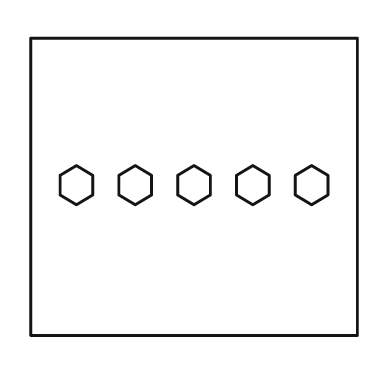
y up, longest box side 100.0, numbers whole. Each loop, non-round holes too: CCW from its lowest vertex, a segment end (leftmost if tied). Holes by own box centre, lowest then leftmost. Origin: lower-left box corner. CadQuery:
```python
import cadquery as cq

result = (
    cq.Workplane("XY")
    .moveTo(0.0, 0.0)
    .lineTo(100.0, 0.0)
    .lineTo(100.0, 91.0)
    .lineTo(0.0, 91.0)
    .close()
    .moveTo(14.0, 40.0)
    .lineTo(19.0, 43.0)
    .lineTo(19.0, 49.0)
    .lineTo(14.0, 52.0)
    .lineTo(9.0, 49.0)
    .lineTo(9.0, 43.0)
    .close()
    .moveTo(32.0, 40.0)
    .lineTo(37.0, 43.0)
    .lineTo(37.0, 49.0)
    .lineTo(32.0, 52.0)
    .lineTo(27.0, 49.0)
    .lineTo(27.0, 43.0)
    .close()
    .moveTo(50.0, 40.0)
    .lineTo(55.0, 43.0)
    .lineTo(55.0, 49.0)
    .lineTo(50.0, 52.0)
    .lineTo(45.0, 49.0)
    .lineTo(45.0, 43.0)
    .close()
    .moveTo(68.0, 40.0)
    .lineTo(73.0, 43.0)
    .lineTo(73.0, 49.0)
    .lineTo(68.0, 52.0)
    .lineTo(63.0, 49.0)
    .lineTo(63.0, 43.0)
    .close()
    .moveTo(86.0, 40.0)
    .lineTo(91.0, 43.0)
    .lineTo(91.0, 49.0)
    .lineTo(86.0, 52.0)
    .lineTo(81.0, 49.0)
    .lineTo(81.0, 43.0)
    .close()
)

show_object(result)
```